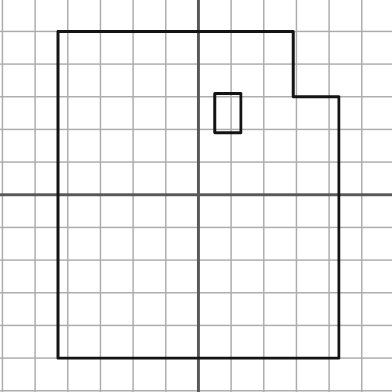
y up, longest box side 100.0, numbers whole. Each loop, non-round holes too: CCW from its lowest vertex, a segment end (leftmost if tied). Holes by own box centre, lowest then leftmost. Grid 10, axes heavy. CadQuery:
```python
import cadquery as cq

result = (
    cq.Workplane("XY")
    .moveTo(-43.0, -50.0)
    .lineTo(43.0, -50.0)
    .lineTo(43.0, 30.0)
    .lineTo(29.0, 30.0)
    .lineTo(29.0, 50.0)
    .lineTo(-43.0, 50.0)
    .close()
    .moveTo(5.0, 19.0)
    .lineTo(13.0, 19.0)
    .lineTo(13.0, 31.0)
    .lineTo(5.0, 31.0)
    .close()
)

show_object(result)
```